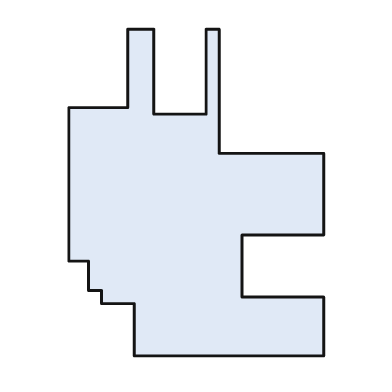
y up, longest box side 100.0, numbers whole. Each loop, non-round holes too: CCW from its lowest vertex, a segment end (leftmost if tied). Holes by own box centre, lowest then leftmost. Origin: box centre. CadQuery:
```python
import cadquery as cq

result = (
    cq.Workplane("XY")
    .moveTo(-19.0, -50.0)
    .lineTo(39.0, -50.0)
    .lineTo(39.0, -32.0)
    .lineTo(14.0, -32.0)
    .lineTo(14.0, -13.0)
    .lineTo(39.0, -13.0)
    .lineTo(39.0, 12.0)
    .lineTo(7.0, 12.0)
    .lineTo(7.0, 50.0)
    .lineTo(3.0, 50.0)
    .lineTo(3.0, 24.0)
    .lineTo(-13.0, 24.0)
    .lineTo(-13.0, 50.0)
    .lineTo(-21.0, 50.0)
    .lineTo(-21.0, 26.0)
    .lineTo(-39.0, 26.0)
    .lineTo(-39.0, -21.0)
    .lineTo(-33.0, -21.0)
    .lineTo(-33.0, -30.0)
    .lineTo(-29.0, -30.0)
    .lineTo(-29.0, -34.0)
    .lineTo(-19.0, -34.0)
    .close()
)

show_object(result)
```